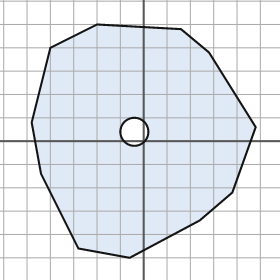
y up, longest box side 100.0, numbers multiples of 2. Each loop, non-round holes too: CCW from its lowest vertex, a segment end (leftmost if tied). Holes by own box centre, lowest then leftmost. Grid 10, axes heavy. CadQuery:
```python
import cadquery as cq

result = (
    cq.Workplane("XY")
    .moveTo(-6.0, -50.0)
    .lineTo(24.0, -34.0)
    .lineTo(38.0, -22.0)
    .lineTo(48.0, 6.0)
    .lineTo(28.0, 38.0)
    .lineTo(16.0, 48.0)
    .lineTo(-20.0, 50.0)
    .lineTo(-40.0, 40.0)
    .lineTo(-48.0, 8.0)
    .lineTo(-44.0, -14.0)
    .lineTo(-28.0, -46.0)
    .close()
    .moveTo(-4.0, 4.0)
    .circle(6.0)
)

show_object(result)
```